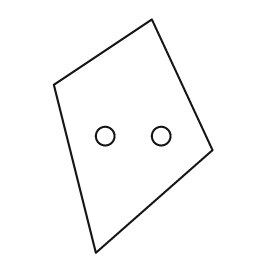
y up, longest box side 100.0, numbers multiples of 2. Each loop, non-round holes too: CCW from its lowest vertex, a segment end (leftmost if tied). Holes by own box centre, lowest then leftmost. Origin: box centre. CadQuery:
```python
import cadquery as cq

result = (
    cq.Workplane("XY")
    .moveTo(-16.0, -50.0)
    .lineTo(34.0, -6.0)
    .lineTo(8.0, 50.0)
    .lineTo(-34.0, 22.0)
    .close()
    .moveTo(-12.0, 0.0)
    .circle(4.0)
    .moveTo(12.0, 0.0)
    .circle(4.0)
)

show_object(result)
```